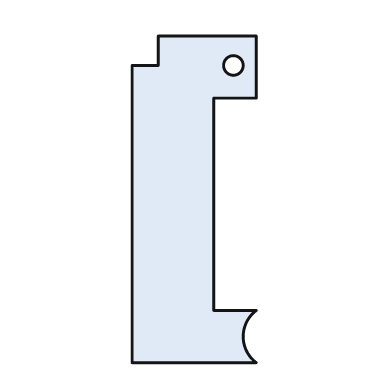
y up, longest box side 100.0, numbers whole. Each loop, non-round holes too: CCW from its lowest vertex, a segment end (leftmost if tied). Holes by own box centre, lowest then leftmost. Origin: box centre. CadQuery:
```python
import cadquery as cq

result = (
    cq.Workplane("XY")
    .moveTo(-19.0, -50.0)
    .lineTo(19.0, -50.0)
    .threePointArc((15.0, -42.0), (19.0, -34.0))
    .lineTo(6.0, -34.0)
    .lineTo(6.0, 31.0)
    .lineTo(19.0, 31.0)
    .lineTo(19.0, 50.0)
    .lineTo(-11.0, 50.0)
    .lineTo(-11.0, 41.0)
    .lineTo(-19.0, 41.0)
    .close()
    .moveTo(12.0, 41.0)
    .circle(3.0)
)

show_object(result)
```